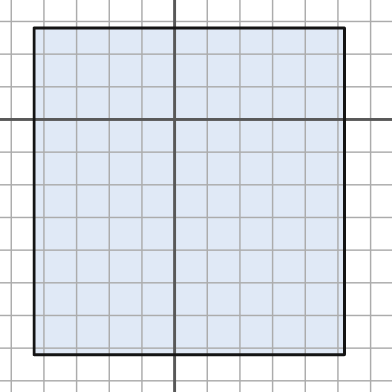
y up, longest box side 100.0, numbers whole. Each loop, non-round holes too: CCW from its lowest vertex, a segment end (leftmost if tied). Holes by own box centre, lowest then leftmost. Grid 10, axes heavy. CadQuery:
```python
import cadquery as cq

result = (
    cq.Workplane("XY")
    .moveTo(-43.0, -72.0)
    .lineTo(52.0, -72.0)
    .lineTo(52.0, 28.0)
    .lineTo(-43.0, 28.0)
    .close()
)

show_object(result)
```